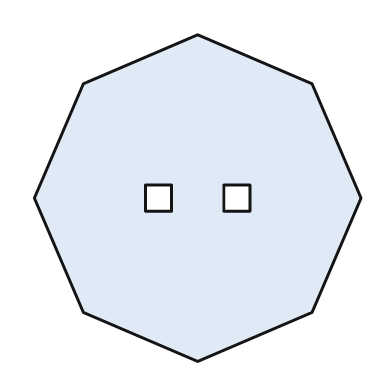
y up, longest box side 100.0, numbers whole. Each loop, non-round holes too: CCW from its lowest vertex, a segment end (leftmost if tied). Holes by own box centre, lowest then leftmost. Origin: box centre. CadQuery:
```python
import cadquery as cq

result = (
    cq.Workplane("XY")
    .moveTo(0.0, -50.0)
    .lineTo(35.0, -35.0)
    .lineTo(50.0, 0.0)
    .lineTo(35.0, 35.0)
    .lineTo(0.0, 50.0)
    .lineTo(-35.0, 35.0)
    .lineTo(-50.0, 0.0)
    .lineTo(-35.0, -35.0)
    .close()
    .moveTo(-16.0, -4.0)
    .lineTo(-8.0, -4.0)
    .lineTo(-8.0, 4.0)
    .lineTo(-16.0, 4.0)
    .close()
    .moveTo(8.0, -4.0)
    .lineTo(16.0, -4.0)
    .lineTo(16.0, 4.0)
    .lineTo(8.0, 4.0)
    .close()
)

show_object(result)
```